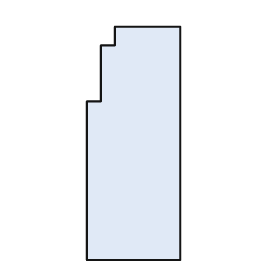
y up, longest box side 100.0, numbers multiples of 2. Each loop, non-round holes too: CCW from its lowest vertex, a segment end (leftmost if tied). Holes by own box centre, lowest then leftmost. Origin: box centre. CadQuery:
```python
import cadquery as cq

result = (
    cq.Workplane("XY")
    .moveTo(-20.0, -50.0)
    .lineTo(20.0, -50.0)
    .lineTo(20.0, 50.0)
    .lineTo(-8.0, 50.0)
    .lineTo(-8.0, 42.0)
    .lineTo(-14.0, 42.0)
    .lineTo(-14.0, 18.0)
    .lineTo(-20.0, 18.0)
    .close()
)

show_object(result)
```